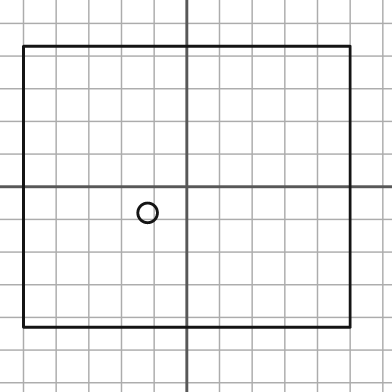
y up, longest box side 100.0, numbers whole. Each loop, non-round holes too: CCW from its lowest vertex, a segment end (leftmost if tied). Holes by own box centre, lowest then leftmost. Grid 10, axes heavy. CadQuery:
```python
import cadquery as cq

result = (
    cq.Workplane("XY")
    .moveTo(-50.0, -43.0)
    .lineTo(50.0, -43.0)
    .lineTo(50.0, 43.0)
    .lineTo(-50.0, 43.0)
    .close()
    .moveTo(-12.0, -8.0)
    .circle(3.0)
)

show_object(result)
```